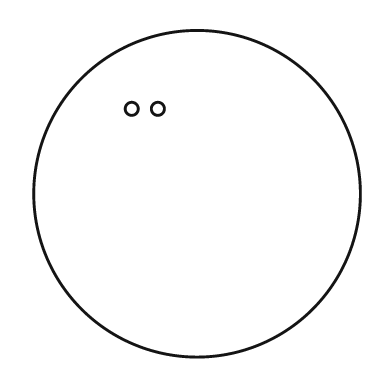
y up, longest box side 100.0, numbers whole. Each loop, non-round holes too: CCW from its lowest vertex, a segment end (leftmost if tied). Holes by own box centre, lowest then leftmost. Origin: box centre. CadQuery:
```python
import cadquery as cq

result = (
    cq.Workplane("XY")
    .moveTo(0.0, 0.0)
    .circle(50.0)
    .moveTo(-20.0, 26.0)
    .circle(2.0)
    .moveTo(-12.0, 26.0)
    .circle(2.0)
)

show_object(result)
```